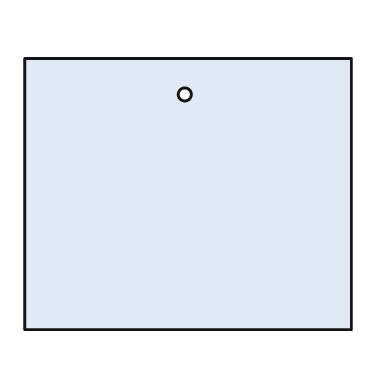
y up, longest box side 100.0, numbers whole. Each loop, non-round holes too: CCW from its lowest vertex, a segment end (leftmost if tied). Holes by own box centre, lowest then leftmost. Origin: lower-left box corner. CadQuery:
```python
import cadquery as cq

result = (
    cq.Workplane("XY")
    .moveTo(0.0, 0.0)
    .lineTo(100.0, 0.0)
    .lineTo(100.0, 83.0)
    .lineTo(0.0, 83.0)
    .close()
    .moveTo(49.0, 72.0)
    .circle(2.0)
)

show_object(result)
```